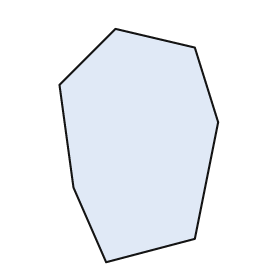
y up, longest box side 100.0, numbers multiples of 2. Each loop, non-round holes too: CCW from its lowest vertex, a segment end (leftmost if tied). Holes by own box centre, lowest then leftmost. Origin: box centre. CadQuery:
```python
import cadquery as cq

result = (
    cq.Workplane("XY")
    .moveTo(-14.0, -50.0)
    .lineTo(24.0, -40.0)
    .lineTo(34.0, 10.0)
    .lineTo(24.0, 42.0)
    .lineTo(-10.0, 50.0)
    .lineTo(-34.0, 26.0)
    .lineTo(-28.0, -18.0)
    .close()
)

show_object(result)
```